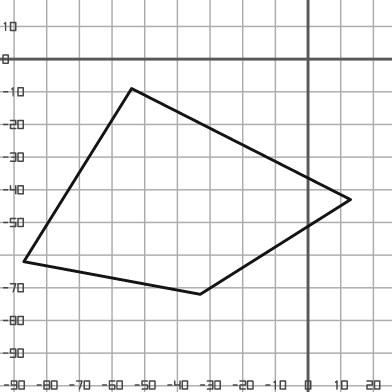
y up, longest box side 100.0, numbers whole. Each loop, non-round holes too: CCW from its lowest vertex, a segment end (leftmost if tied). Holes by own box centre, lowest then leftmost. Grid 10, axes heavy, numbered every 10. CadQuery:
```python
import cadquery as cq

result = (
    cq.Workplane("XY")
    .moveTo(-33.0, -72.0)
    .lineTo(13.0, -43.0)
    .lineTo(-54.0, -9.0)
    .lineTo(-87.0, -62.0)
    .close()
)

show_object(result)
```